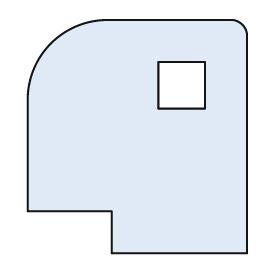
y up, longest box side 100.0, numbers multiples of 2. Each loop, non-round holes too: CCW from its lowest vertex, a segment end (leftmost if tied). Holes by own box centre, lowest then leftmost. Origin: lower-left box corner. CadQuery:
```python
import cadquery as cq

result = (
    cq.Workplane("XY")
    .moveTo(36.0, 0.0)
    .lineTo(94.0, 0.0)
    .lineTo(94.0, 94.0)
    .threePointArc((92.0, 98.0), (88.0, 100.0))
    .lineTo(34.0, 100.0)
    .threePointArc((10.0, 90.0), (0.0, 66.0))
    .lineTo(0.0, 18.0)
    .lineTo(36.0, 18.0)
    .close()
    .moveTo(56.0, 62.0)
    .lineTo(76.0, 62.0)
    .lineTo(76.0, 82.0)
    .lineTo(56.0, 82.0)
    .close()
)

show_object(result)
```